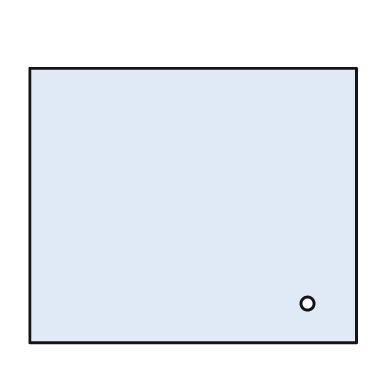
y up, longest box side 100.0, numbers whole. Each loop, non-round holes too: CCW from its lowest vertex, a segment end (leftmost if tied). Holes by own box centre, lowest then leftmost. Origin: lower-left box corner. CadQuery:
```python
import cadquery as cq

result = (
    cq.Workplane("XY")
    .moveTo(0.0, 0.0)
    .lineTo(100.0, 0.0)
    .lineTo(100.0, 84.0)
    .lineTo(0.0, 84.0)
    .close()
    .moveTo(85.0, 12.0)
    .circle(2.0)
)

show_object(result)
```